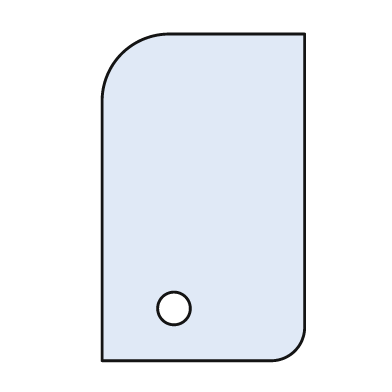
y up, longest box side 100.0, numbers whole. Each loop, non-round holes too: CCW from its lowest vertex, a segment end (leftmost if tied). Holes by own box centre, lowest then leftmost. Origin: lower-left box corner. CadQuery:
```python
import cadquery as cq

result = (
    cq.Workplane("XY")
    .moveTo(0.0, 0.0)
    .lineTo(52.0, 0.0)
    .threePointArc((59.0, 3.0), (62.0, 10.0))
    .lineTo(62.0, 100.0)
    .lineTo(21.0, 100.0)
    .threePointArc((6.0, 94.0), (0.0, 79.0))
    .close()
    .moveTo(22.0, 16.0)
    .circle(5.0)
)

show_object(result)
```